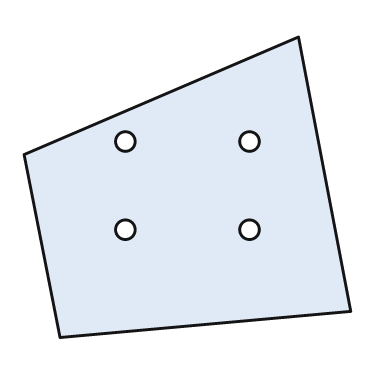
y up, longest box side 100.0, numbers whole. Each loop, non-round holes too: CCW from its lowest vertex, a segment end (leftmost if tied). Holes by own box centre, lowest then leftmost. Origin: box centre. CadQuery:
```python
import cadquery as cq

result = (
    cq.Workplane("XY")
    .moveTo(-39.0, -46.0)
    .lineTo(50.0, -38.0)
    .lineTo(34.0, 46.0)
    .lineTo(-50.0, 10.0)
    .close()
    .moveTo(-19.0, -13.0)
    .circle(3.0)
    .moveTo(19.0, -13.0)
    .circle(3.0)
    .moveTo(-19.0, 14.0)
    .circle(3.0)
    .moveTo(19.0, 14.0)
    .circle(3.0)
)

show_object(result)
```